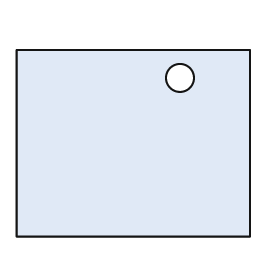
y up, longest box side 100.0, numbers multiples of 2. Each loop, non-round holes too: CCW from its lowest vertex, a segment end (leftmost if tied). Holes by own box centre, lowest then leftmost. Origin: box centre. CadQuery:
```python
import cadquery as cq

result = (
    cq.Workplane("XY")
    .moveTo(-50.0, -40.0)
    .lineTo(50.0, -40.0)
    .lineTo(50.0, 40.0)
    .lineTo(-50.0, 40.0)
    .close()
    .moveTo(20.0, 28.0)
    .circle(6.0)
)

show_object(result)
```